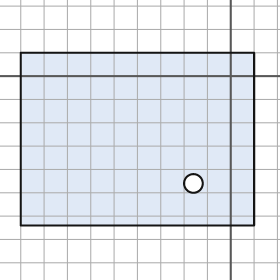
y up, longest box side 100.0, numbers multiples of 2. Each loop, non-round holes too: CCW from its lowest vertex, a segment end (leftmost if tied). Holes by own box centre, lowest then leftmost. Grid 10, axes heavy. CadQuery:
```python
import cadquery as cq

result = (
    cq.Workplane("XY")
    .moveTo(-90.0, -64.0)
    .lineTo(10.0, -64.0)
    .lineTo(10.0, 10.0)
    .lineTo(-90.0, 10.0)
    .close()
    .moveTo(-16.0, -46.0)
    .circle(4.0)
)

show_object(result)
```